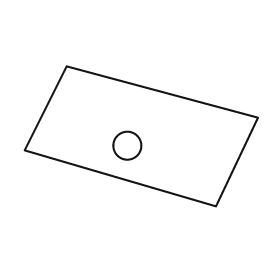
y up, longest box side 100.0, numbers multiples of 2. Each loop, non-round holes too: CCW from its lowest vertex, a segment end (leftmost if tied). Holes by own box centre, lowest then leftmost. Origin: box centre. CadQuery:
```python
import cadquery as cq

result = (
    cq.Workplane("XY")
    .moveTo(32.0, -30.0)
    .lineTo(50.0, 8.0)
    .lineTo(-32.0, 30.0)
    .lineTo(-50.0, -6.0)
    .close()
    .moveTo(-6.0, -4.0)
    .circle(6.0)
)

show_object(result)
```